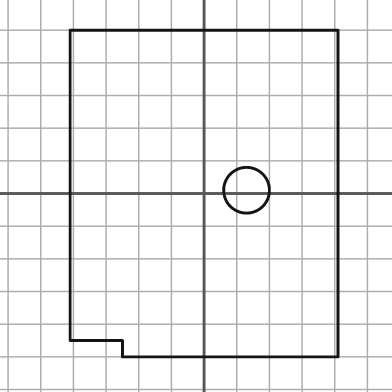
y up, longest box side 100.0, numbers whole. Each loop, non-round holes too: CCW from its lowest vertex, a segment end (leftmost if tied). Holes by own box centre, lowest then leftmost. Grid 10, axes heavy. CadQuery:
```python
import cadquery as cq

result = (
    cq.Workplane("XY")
    .moveTo(-25.0, -50.0)
    .lineTo(41.0, -50.0)
    .lineTo(41.0, 50.0)
    .lineTo(-41.0, 50.0)
    .lineTo(-41.0, -45.0)
    .lineTo(-25.0, -45.0)
    .close()
    .moveTo(13.0, 1.0)
    .circle(7.0)
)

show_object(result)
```